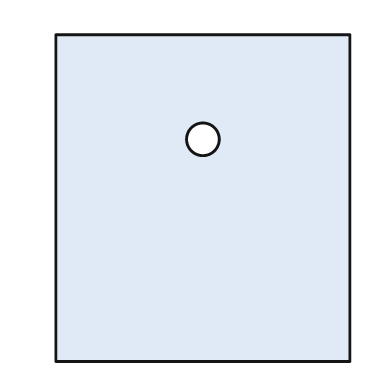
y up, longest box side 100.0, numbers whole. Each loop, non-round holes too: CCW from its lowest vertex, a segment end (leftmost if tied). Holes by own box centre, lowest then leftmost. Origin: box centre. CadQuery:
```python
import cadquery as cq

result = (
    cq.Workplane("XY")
    .moveTo(-45.0, -50.0)
    .lineTo(45.0, -50.0)
    .lineTo(45.0, 50.0)
    .lineTo(-45.0, 50.0)
    .close()
    .moveTo(0.0, 18.0)
    .circle(5.0)
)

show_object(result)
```